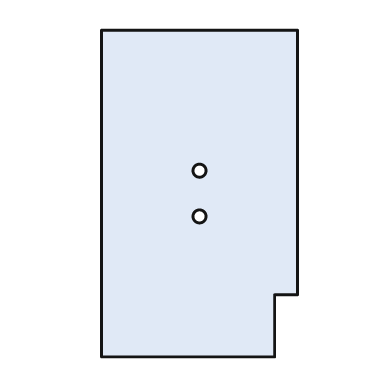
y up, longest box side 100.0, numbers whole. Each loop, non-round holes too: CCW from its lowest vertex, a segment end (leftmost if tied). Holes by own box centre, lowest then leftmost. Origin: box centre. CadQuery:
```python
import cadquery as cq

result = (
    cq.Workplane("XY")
    .moveTo(-30.0, -50.0)
    .lineTo(23.0, -50.0)
    .lineTo(23.0, -31.0)
    .lineTo(30.0, -31.0)
    .lineTo(30.0, 50.0)
    .lineTo(-30.0, 50.0)
    .close()
    .moveTo(0.0, -7.0)
    .circle(2.0)
    .moveTo(0.0, 7.0)
    .circle(2.0)
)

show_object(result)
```